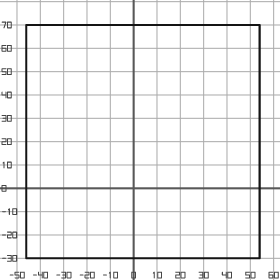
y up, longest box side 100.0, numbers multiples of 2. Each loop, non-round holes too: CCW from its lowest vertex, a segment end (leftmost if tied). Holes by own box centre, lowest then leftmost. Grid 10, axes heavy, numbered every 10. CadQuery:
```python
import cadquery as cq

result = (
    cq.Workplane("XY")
    .moveTo(-46.0, -30.0)
    .lineTo(54.0, -30.0)
    .lineTo(54.0, 70.0)
    .lineTo(-46.0, 70.0)
    .close()
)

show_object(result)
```